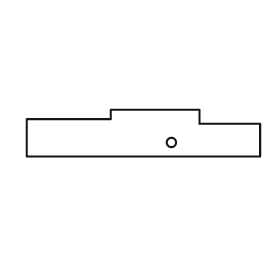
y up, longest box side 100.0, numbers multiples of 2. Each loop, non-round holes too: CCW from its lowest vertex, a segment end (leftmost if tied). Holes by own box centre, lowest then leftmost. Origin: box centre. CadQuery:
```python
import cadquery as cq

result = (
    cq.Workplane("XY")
    .moveTo(-50.0, -10.0)
    .lineTo(50.0, -10.0)
    .lineTo(50.0, 4.0)
    .lineTo(24.0, 4.0)
    .lineTo(24.0, 10.0)
    .lineTo(-14.0, 10.0)
    .lineTo(-14.0, 6.0)
    .lineTo(-50.0, 6.0)
    .close()
    .moveTo(12.0, -4.0)
    .circle(2.0)
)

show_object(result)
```